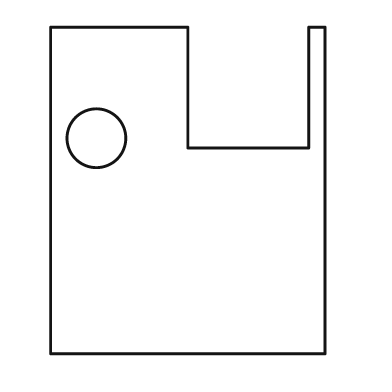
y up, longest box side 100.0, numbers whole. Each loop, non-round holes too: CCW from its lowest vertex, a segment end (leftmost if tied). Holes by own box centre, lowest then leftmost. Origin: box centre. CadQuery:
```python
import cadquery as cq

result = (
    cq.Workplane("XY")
    .moveTo(-42.0, -50.0)
    .lineTo(42.0, -50.0)
    .lineTo(42.0, 50.0)
    .lineTo(37.0, 50.0)
    .lineTo(37.0, 13.0)
    .lineTo(0.0, 13.0)
    .lineTo(0.0, 50.0)
    .lineTo(-42.0, 50.0)
    .close()
    .moveTo(-28.0, 16.0)
    .circle(9.0)
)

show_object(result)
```